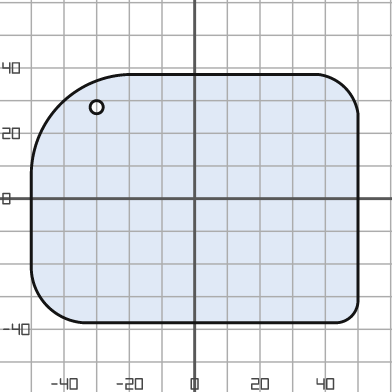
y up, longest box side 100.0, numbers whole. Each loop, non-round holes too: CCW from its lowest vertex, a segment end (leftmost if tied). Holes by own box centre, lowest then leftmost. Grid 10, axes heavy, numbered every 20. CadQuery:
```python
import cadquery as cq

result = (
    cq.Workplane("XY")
    .moveTo(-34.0, -38.0)
    .lineTo(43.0, -38.0)
    .threePointArc((48.0, -36.0), (50.0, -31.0))
    .lineTo(50.0, 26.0)
    .threePointArc((46.0, 34.0), (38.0, 38.0))
    .lineTo(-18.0, 38.0)
    .threePointArc((-41.0, 29.0), (-50.0, 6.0))
    .lineTo(-50.0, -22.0)
    .threePointArc((-45.0, -33.0), (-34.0, -38.0))
    .close()
    .moveTo(-30.0, 28.0)
    .circle(2.0)
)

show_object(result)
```